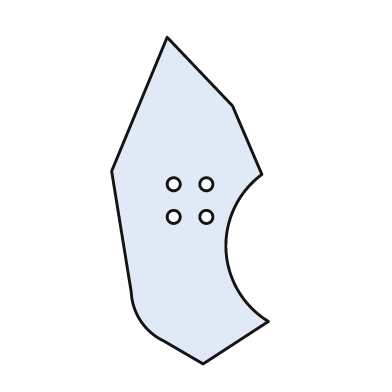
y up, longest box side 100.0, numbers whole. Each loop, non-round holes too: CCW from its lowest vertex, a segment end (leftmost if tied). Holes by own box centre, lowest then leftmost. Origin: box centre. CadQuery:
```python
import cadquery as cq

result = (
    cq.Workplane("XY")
    .moveTo(4.0, -50.0)
    .lineTo(24.0, -37.0)
    .threePointArc((11.0, -15.0), (22.0, 8.0))
    .lineTo(13.0, 29.0)
    .lineTo(-7.0, 50.0)
    .lineTo(-24.0, 9.0)
    .lineTo(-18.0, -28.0)
    .threePointArc((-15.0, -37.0), (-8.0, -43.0))
    .close()
    .moveTo(-5.0, -5.0)
    .circle(2.0)
    .moveTo(5.0, -5.0)
    .circle(2.0)
    .moveTo(-5.0, 5.0)
    .circle(2.0)
    .moveTo(5.0, 5.0)
    .circle(2.0)
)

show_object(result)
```